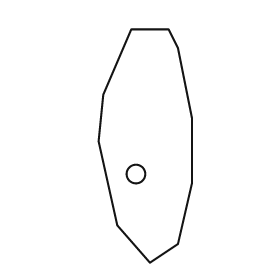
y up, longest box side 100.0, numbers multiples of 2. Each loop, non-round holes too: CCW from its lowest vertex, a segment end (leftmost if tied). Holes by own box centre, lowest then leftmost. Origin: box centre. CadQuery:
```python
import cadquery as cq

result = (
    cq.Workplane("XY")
    .moveTo(2.0, -50.0)
    .lineTo(14.0, -42.0)
    .lineTo(20.0, -16.0)
    .lineTo(20.0, 12.0)
    .lineTo(14.0, 42.0)
    .lineTo(10.0, 50.0)
    .lineTo(-6.0, 50.0)
    .lineTo(-18.0, 22.0)
    .lineTo(-20.0, 2.0)
    .lineTo(-12.0, -34.0)
    .close()
    .moveTo(-4.0, -12.0)
    .circle(4.0)
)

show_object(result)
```